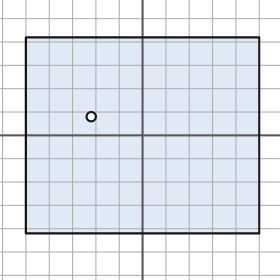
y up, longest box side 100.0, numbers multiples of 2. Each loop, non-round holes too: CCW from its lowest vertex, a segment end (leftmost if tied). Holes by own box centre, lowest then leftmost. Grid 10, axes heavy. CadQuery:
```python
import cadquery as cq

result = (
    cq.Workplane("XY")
    .moveTo(-50.0, -42.0)
    .lineTo(50.0, -42.0)
    .lineTo(50.0, 42.0)
    .lineTo(-50.0, 42.0)
    .close()
    .moveTo(-22.0, 8.0)
    .circle(2.0)
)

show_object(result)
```